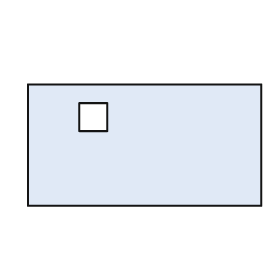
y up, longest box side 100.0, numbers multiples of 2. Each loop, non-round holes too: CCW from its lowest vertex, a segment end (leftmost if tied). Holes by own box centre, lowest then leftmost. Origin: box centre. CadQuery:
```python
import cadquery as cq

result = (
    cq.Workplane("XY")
    .moveTo(-50.0, -26.0)
    .lineTo(50.0, -26.0)
    .lineTo(50.0, 26.0)
    .lineTo(-50.0, 26.0)
    .close()
    .moveTo(-28.0, 6.0)
    .lineTo(-16.0, 6.0)
    .lineTo(-16.0, 18.0)
    .lineTo(-28.0, 18.0)
    .close()
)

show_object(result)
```